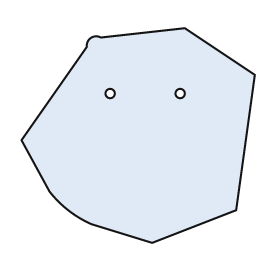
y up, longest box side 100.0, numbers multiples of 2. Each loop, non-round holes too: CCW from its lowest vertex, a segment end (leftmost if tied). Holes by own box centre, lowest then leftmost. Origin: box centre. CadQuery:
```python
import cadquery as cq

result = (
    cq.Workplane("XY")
    .moveTo(6.0, -46.0)
    .lineTo(42.0, -32.0)
    .lineTo(50.0, 26.0)
    .lineTo(20.0, 46.0)
    .lineTo(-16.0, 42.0)
    .threePointArc((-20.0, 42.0), (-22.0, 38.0))
    .lineTo(-50.0, -2.0)
    .lineTo(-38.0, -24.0)
    .threePointArc((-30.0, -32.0), (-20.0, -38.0))
    .close()
    .moveTo(-12.0, 18.0)
    .circle(2.0)
    .moveTo(18.0, 18.0)
    .circle(2.0)
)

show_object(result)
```